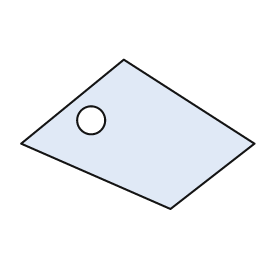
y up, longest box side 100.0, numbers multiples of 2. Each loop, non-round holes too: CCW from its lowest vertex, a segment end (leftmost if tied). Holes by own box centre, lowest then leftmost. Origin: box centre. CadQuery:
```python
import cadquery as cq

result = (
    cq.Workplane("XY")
    .moveTo(14.0, -32.0)
    .lineTo(50.0, -4.0)
    .lineTo(-6.0, 32.0)
    .lineTo(-50.0, -4.0)
    .close()
    .moveTo(-20.0, 6.0)
    .circle(6.0)
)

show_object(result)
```